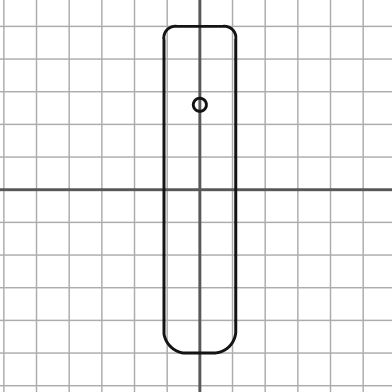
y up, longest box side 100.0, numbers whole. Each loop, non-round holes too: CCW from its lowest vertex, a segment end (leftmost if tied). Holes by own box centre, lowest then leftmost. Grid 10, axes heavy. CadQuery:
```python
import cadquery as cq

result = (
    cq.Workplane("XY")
    .moveTo(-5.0, -50.0)
    .lineTo(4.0, -50.0)
    .threePointArc((9.0, -48.0), (11.0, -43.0))
    .lineTo(11.0, 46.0)
    .threePointArc((10.0, 49.0), (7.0, 50.0))
    .lineTo(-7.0, 50.0)
    .threePointArc((-10.0, 49.0), (-11.0, 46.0))
    .lineTo(-11.0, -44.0)
    .threePointArc((-9.0, -48.0), (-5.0, -50.0))
    .close()
    .moveTo(0.0, 26.0)
    .circle(2.0)
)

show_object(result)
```